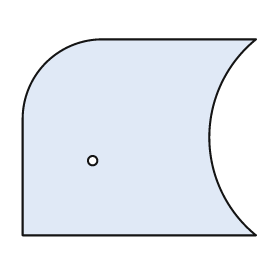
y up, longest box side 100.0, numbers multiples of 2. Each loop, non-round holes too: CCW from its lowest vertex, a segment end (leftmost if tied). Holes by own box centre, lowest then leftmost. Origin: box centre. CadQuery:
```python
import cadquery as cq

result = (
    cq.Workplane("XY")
    .moveTo(-50.0, -42.0)
    .lineTo(50.0, -42.0)
    .threePointArc((30.0, 0.0), (50.0, 42.0))
    .lineTo(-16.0, 42.0)
    .threePointArc((-40.0, 32.0), (-50.0, 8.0))
    .close()
    .moveTo(-20.0, -10.0)
    .circle(2.0)
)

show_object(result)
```